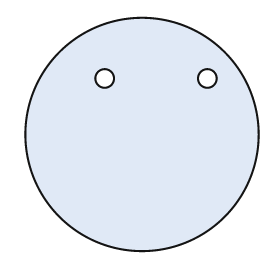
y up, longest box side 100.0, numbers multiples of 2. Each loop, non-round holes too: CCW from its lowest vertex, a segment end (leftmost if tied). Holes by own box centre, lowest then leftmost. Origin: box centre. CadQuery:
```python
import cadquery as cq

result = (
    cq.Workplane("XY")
    .moveTo(0.0, 0.0)
    .circle(50.0)
    .moveTo(-16.0, 24.0)
    .circle(4.0)
    .moveTo(28.0, 24.0)
    .circle(4.0)
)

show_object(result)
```